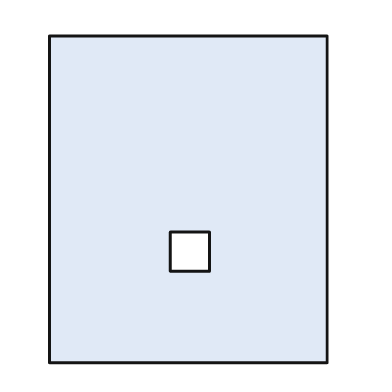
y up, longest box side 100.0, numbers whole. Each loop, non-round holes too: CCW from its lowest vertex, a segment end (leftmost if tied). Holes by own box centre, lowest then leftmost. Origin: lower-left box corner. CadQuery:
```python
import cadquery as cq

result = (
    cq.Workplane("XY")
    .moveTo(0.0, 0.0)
    .lineTo(85.0, 0.0)
    .lineTo(85.0, 100.0)
    .lineTo(0.0, 100.0)
    .close()
    .moveTo(37.0, 28.0)
    .lineTo(49.0, 28.0)
    .lineTo(49.0, 40.0)
    .lineTo(37.0, 40.0)
    .close()
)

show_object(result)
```